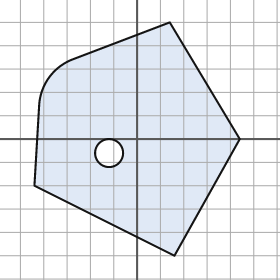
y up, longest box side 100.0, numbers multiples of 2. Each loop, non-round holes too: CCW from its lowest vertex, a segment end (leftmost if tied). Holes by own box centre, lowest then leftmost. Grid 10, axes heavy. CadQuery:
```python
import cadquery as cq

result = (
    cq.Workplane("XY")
    .moveTo(16.0, -50.0)
    .lineTo(44.0, 0.0)
    .lineTo(14.0, 50.0)
    .lineTo(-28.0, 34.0)
    .threePointArc((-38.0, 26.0), (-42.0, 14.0))
    .lineTo(-44.0, -20.0)
    .close()
    .moveTo(-12.0, -6.0)
    .circle(6.0)
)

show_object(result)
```